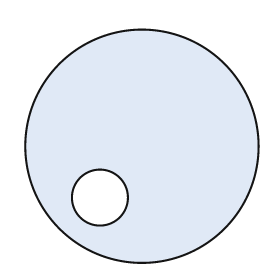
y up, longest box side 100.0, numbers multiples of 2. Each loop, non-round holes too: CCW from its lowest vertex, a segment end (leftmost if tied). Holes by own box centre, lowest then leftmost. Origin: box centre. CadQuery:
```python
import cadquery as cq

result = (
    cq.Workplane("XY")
    .moveTo(0.0, 0.0)
    .circle(50.0)
    .moveTo(-18.0, -22.0)
    .circle(12.0)
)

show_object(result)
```